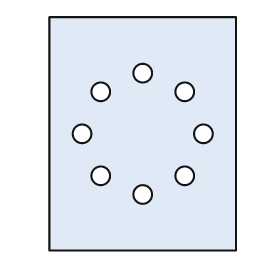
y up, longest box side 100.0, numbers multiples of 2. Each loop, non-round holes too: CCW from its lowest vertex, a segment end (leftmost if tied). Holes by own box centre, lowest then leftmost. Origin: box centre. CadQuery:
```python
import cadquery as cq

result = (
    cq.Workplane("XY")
    .moveTo(-40.0, -50.0)
    .lineTo(40.0, -50.0)
    .lineTo(40.0, 50.0)
    .lineTo(-40.0, 50.0)
    .close()
    .moveTo(0.0, -26.0)
    .circle(4.0)
    .moveTo(-18.0, -18.0)
    .circle(4.0)
    .moveTo(18.0, -18.0)
    .circle(4.0)
    .moveTo(-26.0, 0.0)
    .circle(4.0)
    .moveTo(26.0, 0.0)
    .circle(4.0)
    .moveTo(-18.0, 18.0)
    .circle(4.0)
    .moveTo(18.0, 18.0)
    .circle(4.0)
    .moveTo(0.0, 26.0)
    .circle(4.0)
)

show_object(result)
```